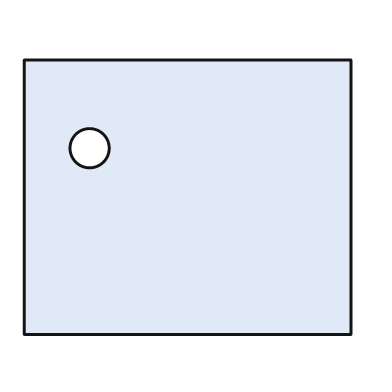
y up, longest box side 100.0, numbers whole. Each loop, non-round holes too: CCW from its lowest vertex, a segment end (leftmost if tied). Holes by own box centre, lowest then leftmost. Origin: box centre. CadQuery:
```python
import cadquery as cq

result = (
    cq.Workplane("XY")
    .moveTo(-50.0, -42.0)
    .lineTo(50.0, -42.0)
    .lineTo(50.0, 42.0)
    .lineTo(-50.0, 42.0)
    .close()
    .moveTo(-30.0, 15.0)
    .circle(6.0)
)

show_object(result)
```